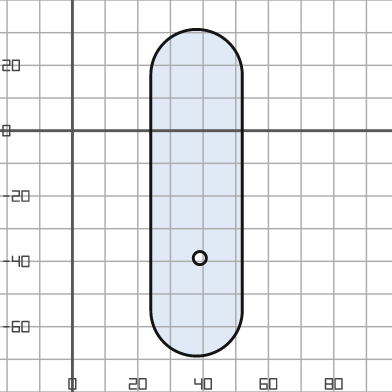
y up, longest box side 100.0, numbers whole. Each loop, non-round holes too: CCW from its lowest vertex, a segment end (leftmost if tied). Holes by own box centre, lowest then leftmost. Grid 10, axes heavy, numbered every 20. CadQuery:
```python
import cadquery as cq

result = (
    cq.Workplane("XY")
    .moveTo(24.0, -55.0)
    .threePointArc((38.0, -69.0), (52.0, -55.0))
    .lineTo(52.0, 17.0)
    .threePointArc((38.0, 31.0), (24.0, 17.0))
    .close()
    .moveTo(39.0, -39.0)
    .circle(2.0)
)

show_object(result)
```